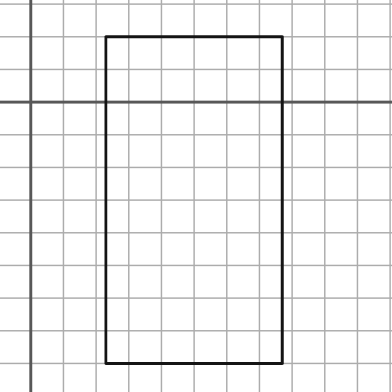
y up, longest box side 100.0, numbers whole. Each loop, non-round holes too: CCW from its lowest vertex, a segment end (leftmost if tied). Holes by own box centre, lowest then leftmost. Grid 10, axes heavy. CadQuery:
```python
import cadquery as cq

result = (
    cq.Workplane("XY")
    .moveTo(23.0, -80.0)
    .lineTo(77.0, -80.0)
    .lineTo(77.0, 20.0)
    .lineTo(23.0, 20.0)
    .close()
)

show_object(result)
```